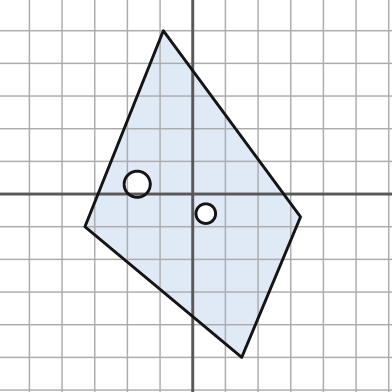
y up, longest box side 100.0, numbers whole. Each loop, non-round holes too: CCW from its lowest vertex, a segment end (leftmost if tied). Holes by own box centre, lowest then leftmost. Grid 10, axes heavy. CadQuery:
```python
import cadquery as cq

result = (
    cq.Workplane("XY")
    .moveTo(15.0, -50.0)
    .lineTo(33.0, -7.0)
    .lineTo(-9.0, 50.0)
    .lineTo(-33.0, -10.0)
    .close()
    .moveTo(4.0, -6.0)
    .circle(3.0)
    .moveTo(-17.0, 3.0)
    .circle(4.0)
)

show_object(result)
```